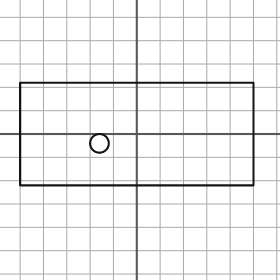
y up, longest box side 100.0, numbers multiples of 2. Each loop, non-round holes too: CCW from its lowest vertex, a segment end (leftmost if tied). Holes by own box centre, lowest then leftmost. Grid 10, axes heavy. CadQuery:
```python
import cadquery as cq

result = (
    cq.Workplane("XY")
    .moveTo(-50.0, -22.0)
    .lineTo(50.0, -22.0)
    .lineTo(50.0, 22.0)
    .lineTo(-50.0, 22.0)
    .close()
    .moveTo(-16.0, -4.0)
    .circle(4.0)
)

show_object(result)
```